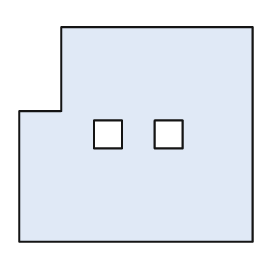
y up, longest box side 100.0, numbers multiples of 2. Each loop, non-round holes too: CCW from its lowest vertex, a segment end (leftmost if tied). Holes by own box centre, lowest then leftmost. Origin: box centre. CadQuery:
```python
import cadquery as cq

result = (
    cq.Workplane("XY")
    .moveTo(-50.0, -46.0)
    .lineTo(50.0, -46.0)
    .lineTo(50.0, 46.0)
    .lineTo(-32.0, 46.0)
    .lineTo(-32.0, 10.0)
    .lineTo(-50.0, 10.0)
    .close()
    .moveTo(-18.0, -6.0)
    .lineTo(-6.0, -6.0)
    .lineTo(-6.0, 6.0)
    .lineTo(-18.0, 6.0)
    .close()
    .moveTo(8.0, -6.0)
    .lineTo(20.0, -6.0)
    .lineTo(20.0, 6.0)
    .lineTo(8.0, 6.0)
    .close()
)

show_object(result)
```